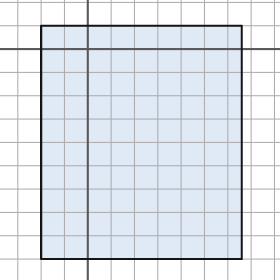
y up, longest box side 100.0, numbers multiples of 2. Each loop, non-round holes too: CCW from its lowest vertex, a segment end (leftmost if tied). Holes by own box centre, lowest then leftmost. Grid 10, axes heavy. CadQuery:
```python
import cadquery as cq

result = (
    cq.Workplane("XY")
    .moveTo(-20.0, -90.0)
    .lineTo(66.0, -90.0)
    .lineTo(66.0, 10.0)
    .lineTo(-20.0, 10.0)
    .close()
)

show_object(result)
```